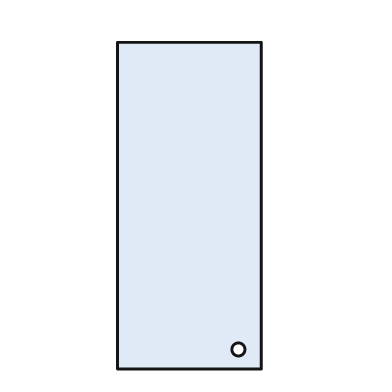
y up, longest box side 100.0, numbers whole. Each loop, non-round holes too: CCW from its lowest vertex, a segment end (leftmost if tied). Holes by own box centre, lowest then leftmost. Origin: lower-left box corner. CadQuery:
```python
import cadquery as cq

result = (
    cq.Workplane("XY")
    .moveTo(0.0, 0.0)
    .lineTo(44.0, 0.0)
    .lineTo(44.0, 100.0)
    .lineTo(0.0, 100.0)
    .close()
    .moveTo(37.0, 6.0)
    .circle(2.0)
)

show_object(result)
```